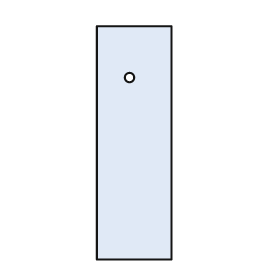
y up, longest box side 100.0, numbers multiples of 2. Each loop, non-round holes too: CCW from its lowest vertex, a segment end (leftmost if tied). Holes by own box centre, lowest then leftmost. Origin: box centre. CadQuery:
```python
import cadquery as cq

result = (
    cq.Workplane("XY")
    .moveTo(-16.0, -50.0)
    .lineTo(16.0, -50.0)
    .lineTo(16.0, 50.0)
    .lineTo(-16.0, 50.0)
    .close()
    .moveTo(-2.0, 28.0)
    .circle(2.0)
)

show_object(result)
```